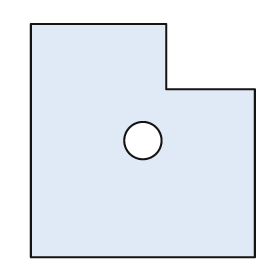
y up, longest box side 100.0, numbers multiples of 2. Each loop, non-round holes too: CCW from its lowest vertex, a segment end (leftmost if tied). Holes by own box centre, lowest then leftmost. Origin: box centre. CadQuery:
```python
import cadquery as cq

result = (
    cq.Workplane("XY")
    .moveTo(-48.0, -50.0)
    .lineTo(48.0, -50.0)
    .lineTo(48.0, 22.0)
    .lineTo(10.0, 22.0)
    .lineTo(10.0, 50.0)
    .lineTo(-48.0, 50.0)
    .close()
    .moveTo(0.0, 0.0)
    .circle(8.0)
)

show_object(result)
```